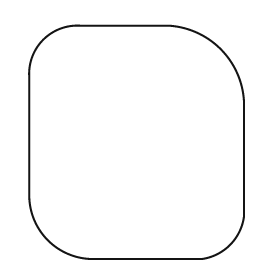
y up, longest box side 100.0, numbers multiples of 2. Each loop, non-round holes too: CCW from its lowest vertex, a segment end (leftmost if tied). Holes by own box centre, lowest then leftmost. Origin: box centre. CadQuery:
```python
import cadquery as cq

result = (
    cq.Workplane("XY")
    .moveTo(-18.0, -50.0)
    .lineTo(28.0, -50.0)
    .threePointArc((40.0, -44.0), (46.0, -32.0))
    .lineTo(46.0, 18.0)
    .threePointArc((36.0, 40.0), (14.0, 50.0))
    .lineTo(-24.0, 50.0)
    .threePointArc((-40.0, 44.0), (-46.0, 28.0))
    .lineTo(-46.0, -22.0)
    .threePointArc((-38.0, -42.0), (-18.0, -50.0))
    .close()
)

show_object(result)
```